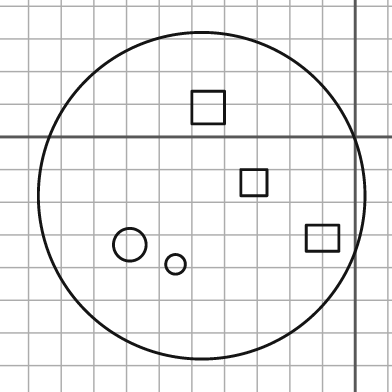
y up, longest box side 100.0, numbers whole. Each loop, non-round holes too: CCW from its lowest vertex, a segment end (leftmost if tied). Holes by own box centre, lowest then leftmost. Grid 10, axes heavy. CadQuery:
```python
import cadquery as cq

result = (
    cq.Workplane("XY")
    .moveTo(-47.0, -18.0)
    .circle(50.0)
    .moveTo(-55.0, -39.0)
    .circle(3.0)
    .moveTo(-69.0, -33.0)
    .circle(5.0)
    .moveTo(-15.0, -35.0)
    .lineTo(-5.0, -35.0)
    .lineTo(-5.0, -27.0)
    .lineTo(-15.0, -27.0)
    .close()
    .moveTo(-35.0, -18.0)
    .lineTo(-27.0, -18.0)
    .lineTo(-27.0, -10.0)
    .lineTo(-35.0, -10.0)
    .close()
    .moveTo(-50.0, 4.0)
    .lineTo(-40.0, 4.0)
    .lineTo(-40.0, 14.0)
    .lineTo(-50.0, 14.0)
    .close()
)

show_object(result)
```